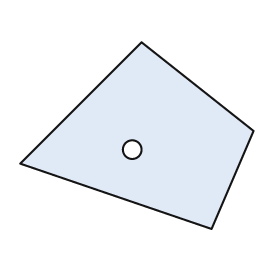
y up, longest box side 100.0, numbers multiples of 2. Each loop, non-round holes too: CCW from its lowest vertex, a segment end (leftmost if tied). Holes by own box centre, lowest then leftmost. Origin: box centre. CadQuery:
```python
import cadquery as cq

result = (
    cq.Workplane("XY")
    .moveTo(32.0, -40.0)
    .lineTo(50.0, 2.0)
    .lineTo(2.0, 40.0)
    .lineTo(-50.0, -12.0)
    .close()
    .moveTo(-2.0, -6.0)
    .circle(4.0)
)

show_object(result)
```